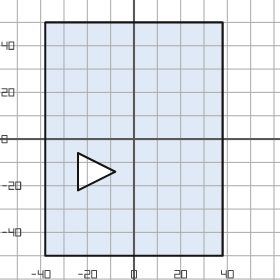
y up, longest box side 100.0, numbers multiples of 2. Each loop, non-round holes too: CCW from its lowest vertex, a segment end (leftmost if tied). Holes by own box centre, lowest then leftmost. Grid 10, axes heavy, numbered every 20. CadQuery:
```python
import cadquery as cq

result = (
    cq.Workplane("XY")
    .moveTo(-38.0, -50.0)
    .lineTo(38.0, -50.0)
    .lineTo(38.0, 50.0)
    .lineTo(-38.0, 50.0)
    .close()
    .moveTo(-24.0, -22.0)
    .lineTo(-8.0, -14.0)
    .lineTo(-24.0, -6.0)
    .close()
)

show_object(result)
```